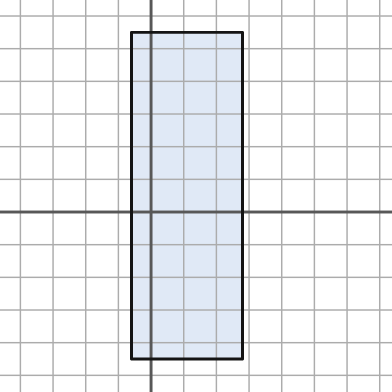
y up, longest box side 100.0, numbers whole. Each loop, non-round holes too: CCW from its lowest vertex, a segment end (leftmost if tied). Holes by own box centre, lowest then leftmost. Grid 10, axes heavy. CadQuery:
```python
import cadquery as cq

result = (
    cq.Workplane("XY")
    .moveTo(-6.0, -45.0)
    .lineTo(28.0, -45.0)
    .lineTo(28.0, 55.0)
    .lineTo(-6.0, 55.0)
    .close()
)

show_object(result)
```